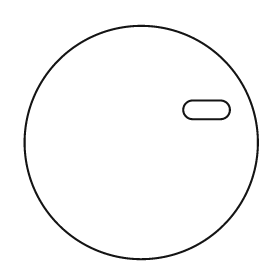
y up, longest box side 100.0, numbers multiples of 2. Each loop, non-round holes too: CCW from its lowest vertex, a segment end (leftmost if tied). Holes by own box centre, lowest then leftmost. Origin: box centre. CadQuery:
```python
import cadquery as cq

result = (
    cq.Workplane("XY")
    .moveTo(0.0, 0.0)
    .circle(50.0)
    .moveTo(22.0, 10.0)
    .lineTo(34.0, 10.0)
    .threePointArc((38.0, 14.0), (34.0, 18.0))
    .lineTo(22.0, 18.0)
    .threePointArc((18.0, 14.0), (22.0, 10.0))
    .close()
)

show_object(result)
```